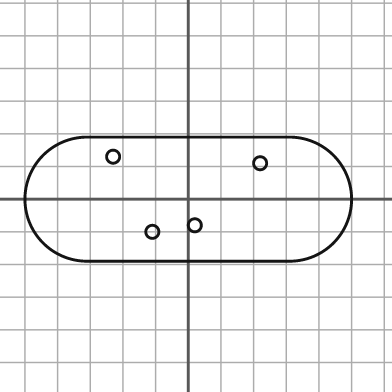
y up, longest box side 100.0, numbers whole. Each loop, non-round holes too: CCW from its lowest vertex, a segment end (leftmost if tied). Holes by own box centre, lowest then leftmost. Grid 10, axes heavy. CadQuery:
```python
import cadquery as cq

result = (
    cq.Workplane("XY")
    .moveTo(-31.0, -19.0)
    .lineTo(31.0, -19.0)
    .threePointArc((50.0, 0.0), (31.0, 19.0))
    .lineTo(-31.0, 19.0)
    .threePointArc((-50.0, 0.0), (-31.0, -19.0))
    .close()
    .moveTo(-11.0, -10.0)
    .circle(2.0)
    .moveTo(2.0, -8.0)
    .circle(2.0)
    .moveTo(22.0, 11.0)
    .circle(2.0)
    .moveTo(-23.0, 13.0)
    .circle(2.0)
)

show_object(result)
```